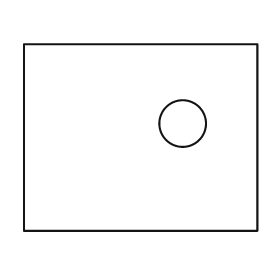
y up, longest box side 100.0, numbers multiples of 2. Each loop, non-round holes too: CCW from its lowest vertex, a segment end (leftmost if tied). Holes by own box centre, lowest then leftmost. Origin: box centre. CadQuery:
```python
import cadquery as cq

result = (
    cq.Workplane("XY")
    .moveTo(-50.0, -40.0)
    .lineTo(50.0, -40.0)
    .lineTo(50.0, 40.0)
    .lineTo(-50.0, 40.0)
    .close()
    .moveTo(18.0, 6.0)
    .circle(10.0)
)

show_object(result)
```